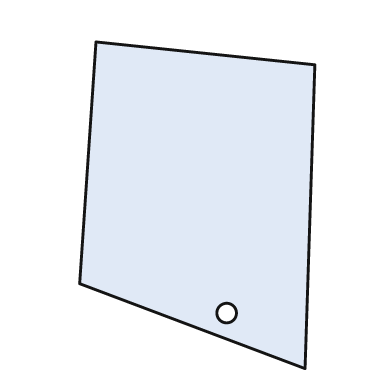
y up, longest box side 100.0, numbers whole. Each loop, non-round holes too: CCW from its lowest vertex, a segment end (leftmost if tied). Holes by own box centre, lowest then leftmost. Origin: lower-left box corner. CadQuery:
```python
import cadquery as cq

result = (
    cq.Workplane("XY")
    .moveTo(69.0, 0.0)
    .lineTo(72.0, 93.0)
    .lineTo(5.0, 100.0)
    .lineTo(0.0, 26.0)
    .close()
    .moveTo(45.0, 17.0)
    .circle(3.0)
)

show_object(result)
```